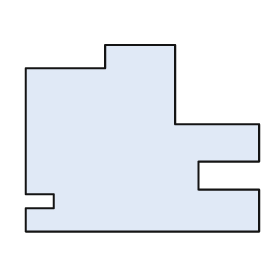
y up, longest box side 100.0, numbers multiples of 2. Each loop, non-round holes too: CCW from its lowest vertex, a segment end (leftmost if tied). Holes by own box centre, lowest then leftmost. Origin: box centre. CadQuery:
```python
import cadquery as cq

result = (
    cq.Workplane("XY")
    .moveTo(-50.0, -40.0)
    .lineTo(50.0, -40.0)
    .lineTo(50.0, -22.0)
    .lineTo(24.0, -22.0)
    .lineTo(24.0, -10.0)
    .lineTo(50.0, -10.0)
    .lineTo(50.0, 6.0)
    .lineTo(14.0, 6.0)
    .lineTo(14.0, 40.0)
    .lineTo(-16.0, 40.0)
    .lineTo(-16.0, 30.0)
    .lineTo(-50.0, 30.0)
    .lineTo(-50.0, -24.0)
    .lineTo(-38.0, -24.0)
    .lineTo(-38.0, -30.0)
    .lineTo(-50.0, -30.0)
    .close()
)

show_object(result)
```